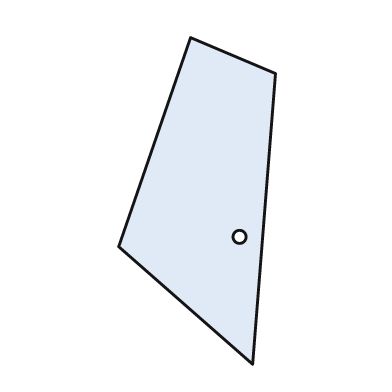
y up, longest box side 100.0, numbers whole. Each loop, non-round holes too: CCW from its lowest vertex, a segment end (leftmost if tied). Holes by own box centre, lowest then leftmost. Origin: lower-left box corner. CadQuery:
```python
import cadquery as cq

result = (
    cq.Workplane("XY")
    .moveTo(41.0, 0.0)
    .lineTo(48.0, 89.0)
    .lineTo(22.0, 100.0)
    .lineTo(0.0, 36.0)
    .close()
    .moveTo(37.0, 39.0)
    .circle(2.0)
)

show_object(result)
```